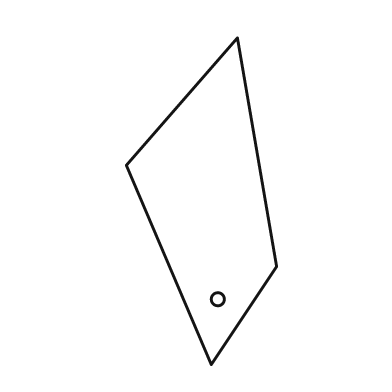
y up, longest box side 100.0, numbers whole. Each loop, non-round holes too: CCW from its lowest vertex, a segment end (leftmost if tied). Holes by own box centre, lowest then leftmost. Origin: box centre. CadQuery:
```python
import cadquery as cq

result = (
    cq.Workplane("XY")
    .moveTo(3.0, -50.0)
    .lineTo(23.0, -20.0)
    .lineTo(11.0, 50.0)
    .lineTo(-23.0, 11.0)
    .close()
    .moveTo(5.0, -30.0)
    .circle(2.0)
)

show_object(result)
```